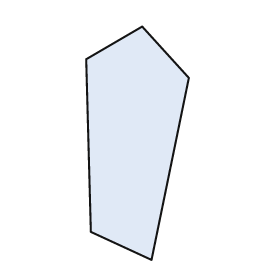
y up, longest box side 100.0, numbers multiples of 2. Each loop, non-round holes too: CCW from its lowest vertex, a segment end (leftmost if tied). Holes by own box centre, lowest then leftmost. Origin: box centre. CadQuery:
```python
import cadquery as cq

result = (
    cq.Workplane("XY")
    .moveTo(6.0, -50.0)
    .lineTo(22.0, 28.0)
    .lineTo(2.0, 50.0)
    .lineTo(-22.0, 36.0)
    .lineTo(-20.0, -38.0)
    .close()
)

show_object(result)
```